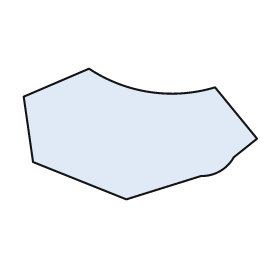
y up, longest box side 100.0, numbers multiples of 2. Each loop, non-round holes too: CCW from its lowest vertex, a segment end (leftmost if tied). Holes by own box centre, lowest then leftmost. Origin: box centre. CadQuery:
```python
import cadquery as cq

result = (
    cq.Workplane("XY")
    .moveTo(-6.0, -28.0)
    .lineTo(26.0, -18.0)
    .threePointArc((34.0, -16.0), (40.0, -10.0))
    .lineTo(50.0, -2.0)
    .lineTo(32.0, 20.0)
    .threePointArc((4.0, 18.0), (-22.0, 28.0))
    .lineTo(-50.0, 16.0)
    .lineTo(-46.0, -12.0)
    .close()
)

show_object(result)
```